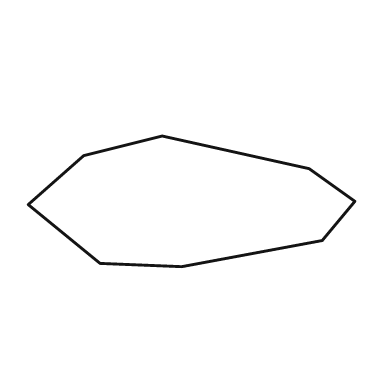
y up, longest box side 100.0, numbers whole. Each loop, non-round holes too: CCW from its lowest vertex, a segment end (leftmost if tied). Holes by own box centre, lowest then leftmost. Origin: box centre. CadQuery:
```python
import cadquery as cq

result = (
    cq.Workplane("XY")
    .moveTo(-3.0, -20.0)
    .lineTo(40.0, -12.0)
    .lineTo(50.0, 0.0)
    .lineTo(36.0, 10.0)
    .lineTo(-9.0, 20.0)
    .lineTo(-33.0, 14.0)
    .lineTo(-50.0, -1.0)
    .lineTo(-28.0, -19.0)
    .close()
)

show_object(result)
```